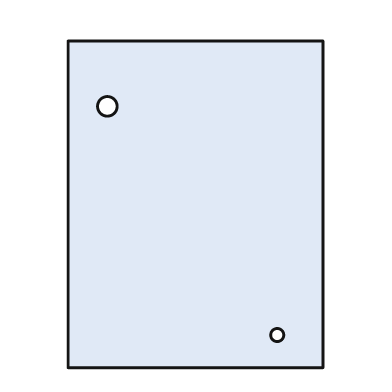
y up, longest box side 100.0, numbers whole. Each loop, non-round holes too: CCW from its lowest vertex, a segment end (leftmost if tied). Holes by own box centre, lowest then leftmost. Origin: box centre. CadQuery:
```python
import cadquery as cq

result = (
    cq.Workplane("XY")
    .moveTo(-39.0, -50.0)
    .lineTo(39.0, -50.0)
    .lineTo(39.0, 50.0)
    .lineTo(-39.0, 50.0)
    .close()
    .moveTo(25.0, -40.0)
    .circle(2.0)
    .moveTo(-27.0, 30.0)
    .circle(3.0)
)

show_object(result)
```